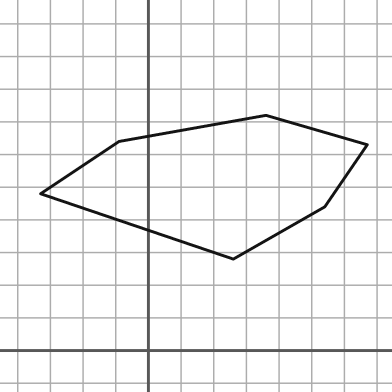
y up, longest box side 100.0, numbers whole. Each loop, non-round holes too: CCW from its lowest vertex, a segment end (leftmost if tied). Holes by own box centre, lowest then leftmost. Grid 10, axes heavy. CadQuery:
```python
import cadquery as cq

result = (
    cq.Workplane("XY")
    .moveTo(26.0, 28.0)
    .lineTo(54.0, 44.0)
    .lineTo(67.0, 63.0)
    .lineTo(36.0, 72.0)
    .lineTo(-9.0, 64.0)
    .lineTo(-33.0, 48.0)
    .close()
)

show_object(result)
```